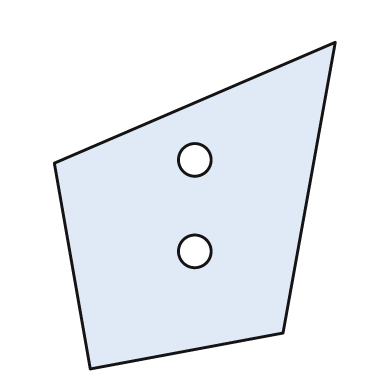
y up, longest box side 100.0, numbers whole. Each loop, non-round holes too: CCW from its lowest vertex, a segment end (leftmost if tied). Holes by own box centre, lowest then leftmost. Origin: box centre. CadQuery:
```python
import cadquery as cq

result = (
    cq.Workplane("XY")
    .moveTo(-32.0, -50.0)
    .lineTo(27.0, -39.0)
    .lineTo(43.0, 50.0)
    .lineTo(-43.0, 13.0)
    .close()
    .moveTo(0.0, -14.0)
    .circle(5.0)
    .moveTo(0.0, 14.0)
    .circle(5.0)
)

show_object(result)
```